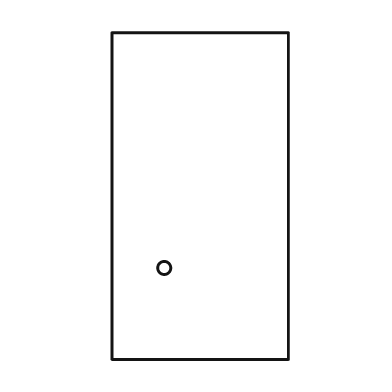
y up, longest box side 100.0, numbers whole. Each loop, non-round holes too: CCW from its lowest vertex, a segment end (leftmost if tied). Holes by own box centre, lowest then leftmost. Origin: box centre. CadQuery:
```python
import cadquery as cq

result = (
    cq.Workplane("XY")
    .moveTo(-27.0, -50.0)
    .lineTo(27.0, -50.0)
    .lineTo(27.0, 50.0)
    .lineTo(-27.0, 50.0)
    .close()
    .moveTo(-11.0, -22.0)
    .circle(2.0)
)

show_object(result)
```